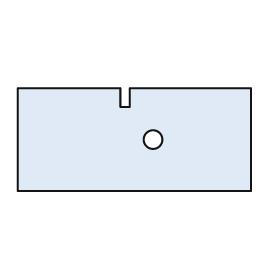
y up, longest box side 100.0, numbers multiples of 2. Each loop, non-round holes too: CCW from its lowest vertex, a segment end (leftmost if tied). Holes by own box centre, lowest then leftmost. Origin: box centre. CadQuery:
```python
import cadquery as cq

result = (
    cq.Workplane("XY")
    .moveTo(-50.0, -22.0)
    .lineTo(50.0, -22.0)
    .lineTo(50.0, 22.0)
    .lineTo(-2.0, 22.0)
    .lineTo(-2.0, 14.0)
    .lineTo(-6.0, 14.0)
    .lineTo(-6.0, 22.0)
    .lineTo(-50.0, 22.0)
    .close()
    .moveTo(8.0, 0.0)
    .circle(4.0)
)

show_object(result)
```